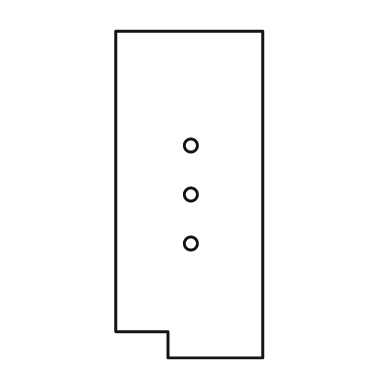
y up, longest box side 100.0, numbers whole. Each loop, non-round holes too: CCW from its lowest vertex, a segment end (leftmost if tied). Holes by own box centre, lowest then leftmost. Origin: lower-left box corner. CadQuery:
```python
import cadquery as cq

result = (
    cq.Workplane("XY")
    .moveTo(16.0, 0.0)
    .lineTo(45.0, 0.0)
    .lineTo(45.0, 100.0)
    .lineTo(0.0, 100.0)
    .lineTo(0.0, 8.0)
    .lineTo(16.0, 8.0)
    .close()
    .moveTo(23.0, 35.0)
    .circle(2.0)
    .moveTo(23.0, 50.0)
    .circle(2.0)
    .moveTo(23.0, 65.0)
    .circle(2.0)
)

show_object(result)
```